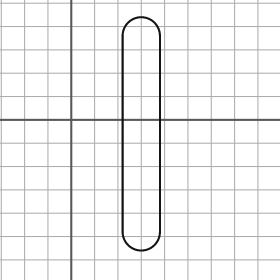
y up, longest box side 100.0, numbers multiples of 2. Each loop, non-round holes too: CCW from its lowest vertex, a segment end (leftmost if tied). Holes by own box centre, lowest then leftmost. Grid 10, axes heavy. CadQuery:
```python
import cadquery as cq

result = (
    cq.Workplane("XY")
    .moveTo(22.0, -48.0)
    .threePointArc((30.0, -56.0), (38.0, -48.0))
    .lineTo(38.0, 36.0)
    .threePointArc((30.0, 44.0), (22.0, 36.0))
    .close()
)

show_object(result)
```